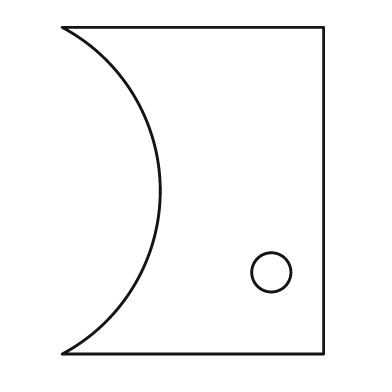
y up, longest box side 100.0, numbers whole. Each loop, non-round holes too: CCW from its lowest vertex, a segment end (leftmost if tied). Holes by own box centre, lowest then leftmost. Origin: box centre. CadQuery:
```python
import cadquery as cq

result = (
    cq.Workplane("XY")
    .moveTo(-40.0, -50.0)
    .lineTo(40.0, -50.0)
    .lineTo(40.0, 50.0)
    .lineTo(-40.0, 50.0)
    .threePointArc((-10.0, 0.0), (-40.0, -50.0))
    .close()
    .moveTo(24.0, -25.0)
    .circle(6.0)
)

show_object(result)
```